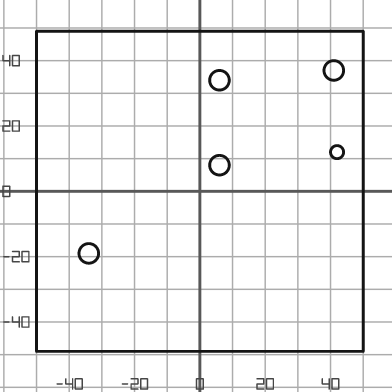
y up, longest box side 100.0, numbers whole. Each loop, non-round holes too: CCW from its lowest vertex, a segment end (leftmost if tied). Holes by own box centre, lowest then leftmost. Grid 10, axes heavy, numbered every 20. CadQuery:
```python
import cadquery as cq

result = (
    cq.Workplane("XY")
    .moveTo(-50.0, -49.0)
    .lineTo(50.0, -49.0)
    .lineTo(50.0, 49.0)
    .lineTo(-50.0, 49.0)
    .close()
    .moveTo(-34.0, -19.0)
    .circle(3.0)
    .moveTo(6.0, 8.0)
    .circle(3.0)
    .moveTo(42.0, 12.0)
    .circle(2.0)
    .moveTo(6.0, 34.0)
    .circle(3.0)
    .moveTo(41.0, 37.0)
    .circle(3.0)
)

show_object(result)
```